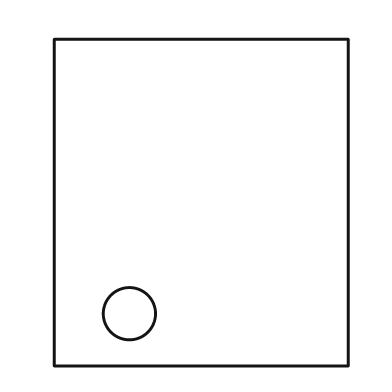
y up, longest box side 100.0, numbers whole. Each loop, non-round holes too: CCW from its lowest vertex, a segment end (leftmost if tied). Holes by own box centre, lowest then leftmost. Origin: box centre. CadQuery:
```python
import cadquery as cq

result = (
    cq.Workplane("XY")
    .moveTo(-45.0, -50.0)
    .lineTo(45.0, -50.0)
    .lineTo(45.0, 50.0)
    .lineTo(-45.0, 50.0)
    .close()
    .moveTo(-22.0, -34.0)
    .circle(8.0)
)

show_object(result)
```